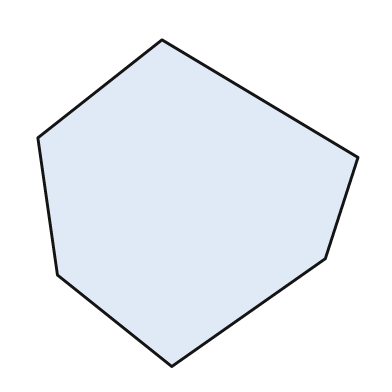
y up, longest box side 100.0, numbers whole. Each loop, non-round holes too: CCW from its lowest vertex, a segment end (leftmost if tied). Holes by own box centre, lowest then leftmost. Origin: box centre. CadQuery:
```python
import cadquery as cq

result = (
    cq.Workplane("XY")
    .moveTo(-8.0, -50.0)
    .lineTo(39.0, -17.0)
    .lineTo(49.0, 14.0)
    .lineTo(-11.0, 50.0)
    .lineTo(-49.0, 20.0)
    .lineTo(-43.0, -22.0)
    .close()
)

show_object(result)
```